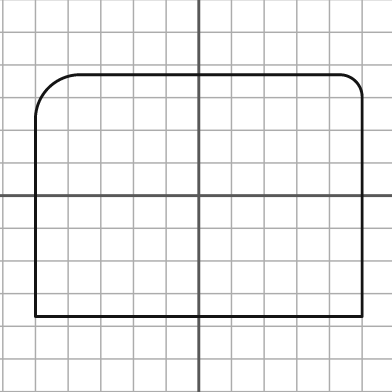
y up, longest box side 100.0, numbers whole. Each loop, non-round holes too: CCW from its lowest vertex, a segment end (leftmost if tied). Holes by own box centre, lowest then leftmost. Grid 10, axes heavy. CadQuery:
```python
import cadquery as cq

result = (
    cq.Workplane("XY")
    .moveTo(-50.0, -37.0)
    .lineTo(50.0, -37.0)
    .lineTo(50.0, 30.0)
    .threePointArc((48.0, 35.0), (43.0, 37.0))
    .lineTo(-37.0, 37.0)
    .threePointArc((-46.0, 33.0), (-50.0, 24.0))
    .close()
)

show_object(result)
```